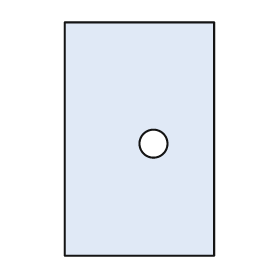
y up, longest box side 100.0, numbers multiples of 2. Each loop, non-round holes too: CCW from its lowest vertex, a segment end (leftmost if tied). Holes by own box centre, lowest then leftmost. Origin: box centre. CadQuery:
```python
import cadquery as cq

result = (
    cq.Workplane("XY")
    .moveTo(-32.0, -50.0)
    .lineTo(32.0, -50.0)
    .lineTo(32.0, 50.0)
    .lineTo(-32.0, 50.0)
    .close()
    .moveTo(6.0, -2.0)
    .circle(6.0)
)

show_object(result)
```